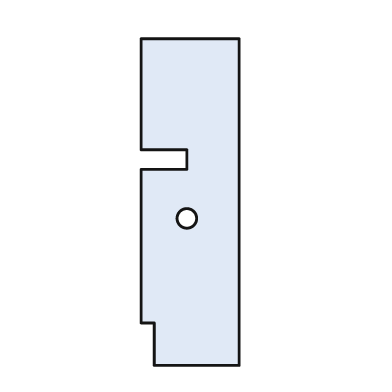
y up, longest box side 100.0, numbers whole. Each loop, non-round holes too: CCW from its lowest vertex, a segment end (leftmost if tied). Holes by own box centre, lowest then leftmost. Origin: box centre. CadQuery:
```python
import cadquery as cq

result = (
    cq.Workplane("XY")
    .moveTo(-11.0, -50.0)
    .lineTo(15.0, -50.0)
    .lineTo(15.0, 50.0)
    .lineTo(-15.0, 50.0)
    .lineTo(-15.0, 16.0)
    .lineTo(-1.0, 16.0)
    .lineTo(-1.0, 10.0)
    .lineTo(-15.0, 10.0)
    .lineTo(-15.0, -37.0)
    .lineTo(-11.0, -37.0)
    .close()
    .moveTo(-1.0, -5.0)
    .circle(3.0)
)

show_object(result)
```